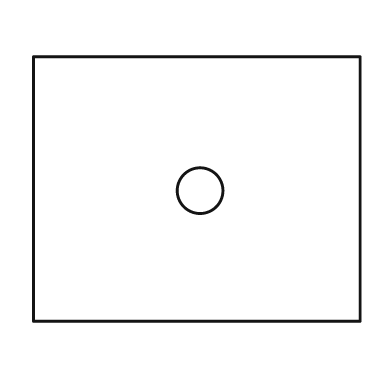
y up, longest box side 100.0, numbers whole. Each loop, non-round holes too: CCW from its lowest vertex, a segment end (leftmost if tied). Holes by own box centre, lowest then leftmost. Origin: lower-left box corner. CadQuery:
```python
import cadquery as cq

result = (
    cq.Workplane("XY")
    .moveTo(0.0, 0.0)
    .lineTo(100.0, 0.0)
    .lineTo(100.0, 81.0)
    .lineTo(0.0, 81.0)
    .close()
    .moveTo(51.0, 40.0)
    .circle(7.0)
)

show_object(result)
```